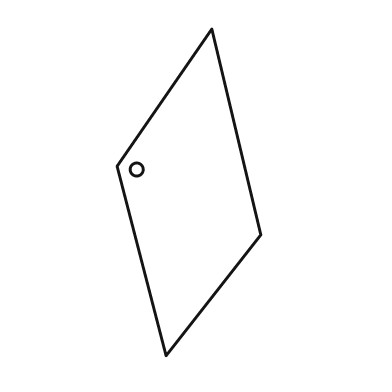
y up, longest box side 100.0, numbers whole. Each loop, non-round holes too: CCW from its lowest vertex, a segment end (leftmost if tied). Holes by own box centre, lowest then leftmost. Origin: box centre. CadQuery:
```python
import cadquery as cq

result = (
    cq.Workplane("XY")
    .moveTo(-7.0, -50.0)
    .lineTo(22.0, -13.0)
    .lineTo(7.0, 50.0)
    .lineTo(-22.0, 8.0)
    .close()
    .moveTo(-16.0, 7.0)
    .circle(2.0)
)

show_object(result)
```